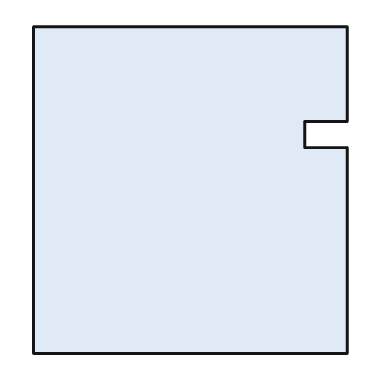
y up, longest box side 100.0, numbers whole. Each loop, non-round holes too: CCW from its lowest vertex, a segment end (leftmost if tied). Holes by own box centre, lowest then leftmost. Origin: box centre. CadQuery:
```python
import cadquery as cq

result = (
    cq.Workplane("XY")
    .moveTo(-48.0, -50.0)
    .lineTo(48.0, -50.0)
    .lineTo(48.0, 13.0)
    .lineTo(35.0, 13.0)
    .lineTo(35.0, 21.0)
    .lineTo(48.0, 21.0)
    .lineTo(48.0, 50.0)
    .lineTo(-48.0, 50.0)
    .close()
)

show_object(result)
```